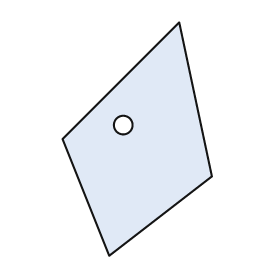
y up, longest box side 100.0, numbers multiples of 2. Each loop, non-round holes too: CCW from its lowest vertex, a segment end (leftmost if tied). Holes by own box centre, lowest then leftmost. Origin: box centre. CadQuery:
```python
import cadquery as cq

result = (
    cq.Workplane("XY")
    .moveTo(-12.0, -50.0)
    .lineTo(32.0, -16.0)
    .lineTo(18.0, 50.0)
    .lineTo(-32.0, 0.0)
    .close()
    .moveTo(-6.0, 6.0)
    .circle(4.0)
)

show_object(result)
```